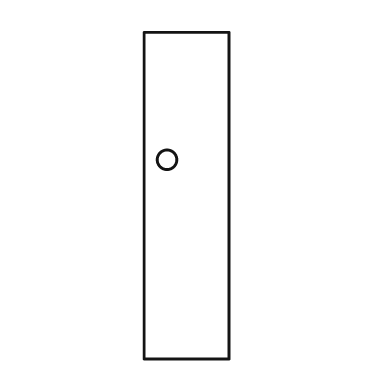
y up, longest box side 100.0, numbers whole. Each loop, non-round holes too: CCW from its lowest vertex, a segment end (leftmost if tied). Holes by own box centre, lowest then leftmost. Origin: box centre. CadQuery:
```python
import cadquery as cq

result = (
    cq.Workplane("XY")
    .moveTo(-13.0, -50.0)
    .lineTo(13.0, -50.0)
    .lineTo(13.0, 50.0)
    .lineTo(-13.0, 50.0)
    .close()
    .moveTo(-6.0, 11.0)
    .circle(3.0)
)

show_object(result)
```